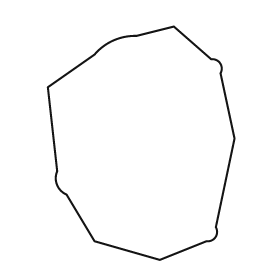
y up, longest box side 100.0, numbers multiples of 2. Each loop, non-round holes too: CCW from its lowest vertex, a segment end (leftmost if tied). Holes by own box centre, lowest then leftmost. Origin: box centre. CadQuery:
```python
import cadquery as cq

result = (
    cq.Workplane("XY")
    .moveTo(8.0, -50.0)
    .lineTo(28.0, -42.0)
    .threePointArc((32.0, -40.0), (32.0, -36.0))
    .lineTo(40.0, 2.0)
    .lineTo(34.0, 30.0)
    .threePointArc((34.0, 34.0), (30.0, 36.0))
    .lineTo(14.0, 50.0)
    .lineTo(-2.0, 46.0)
    .threePointArc((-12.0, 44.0), (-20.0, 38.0))
    .lineTo(-40.0, 24.0)
    .lineTo(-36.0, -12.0)
    .threePointArc((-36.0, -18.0), (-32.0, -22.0))
    .lineTo(-20.0, -42.0)
    .close()
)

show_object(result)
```